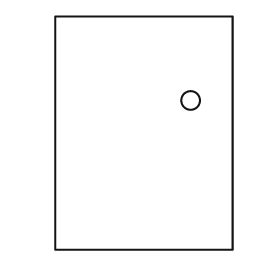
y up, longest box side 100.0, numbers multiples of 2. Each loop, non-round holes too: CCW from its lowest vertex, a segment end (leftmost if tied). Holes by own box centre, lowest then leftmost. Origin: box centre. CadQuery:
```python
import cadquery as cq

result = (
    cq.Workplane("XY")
    .moveTo(-38.0, -50.0)
    .lineTo(38.0, -50.0)
    .lineTo(38.0, 50.0)
    .lineTo(-38.0, 50.0)
    .close()
    .moveTo(20.0, 14.0)
    .circle(4.0)
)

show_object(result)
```